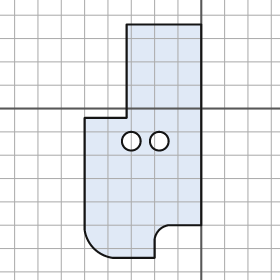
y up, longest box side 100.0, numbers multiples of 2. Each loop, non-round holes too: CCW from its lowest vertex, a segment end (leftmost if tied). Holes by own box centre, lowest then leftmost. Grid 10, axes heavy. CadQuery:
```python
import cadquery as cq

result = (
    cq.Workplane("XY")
    .moveTo(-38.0, -64.0)
    .lineTo(-20.0, -64.0)
    .lineTo(-20.0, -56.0)
    .threePointArc((-18.0, -52.0), (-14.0, -50.0))
    .lineTo(0.0, -50.0)
    .lineTo(0.0, 36.0)
    .lineTo(-32.0, 36.0)
    .lineTo(-32.0, -4.0)
    .lineTo(-50.0, -4.0)
    .lineTo(-50.0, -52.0)
    .threePointArc((-46.0, -60.0), (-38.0, -64.0))
    .close()
    .moveTo(-30.0, -14.0)
    .circle(4.0)
    .moveTo(-18.0, -14.0)
    .circle(4.0)
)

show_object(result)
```